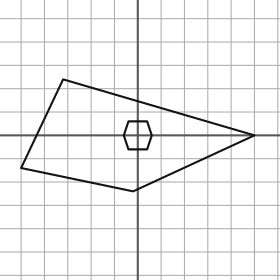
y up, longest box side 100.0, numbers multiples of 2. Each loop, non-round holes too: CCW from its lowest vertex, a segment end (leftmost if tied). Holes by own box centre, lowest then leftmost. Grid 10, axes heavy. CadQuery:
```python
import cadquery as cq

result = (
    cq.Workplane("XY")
    .moveTo(-2.0, -24.0)
    .lineTo(50.0, 0.0)
    .lineTo(-32.0, 24.0)
    .lineTo(-50.0, -14.0)
    .close()
    .moveTo(-4.0, -6.0)
    .lineTo(4.0, -6.0)
    .lineTo(6.0, 0.0)
    .lineTo(4.0, 6.0)
    .lineTo(-4.0, 6.0)
    .lineTo(-6.0, 0.0)
    .close()
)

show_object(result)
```